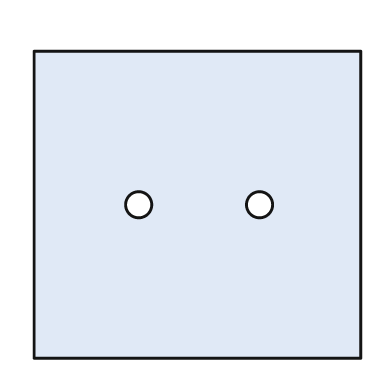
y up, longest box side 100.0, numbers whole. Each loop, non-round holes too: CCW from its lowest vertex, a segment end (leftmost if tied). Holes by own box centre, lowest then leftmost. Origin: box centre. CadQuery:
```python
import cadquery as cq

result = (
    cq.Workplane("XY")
    .moveTo(-50.0, -47.0)
    .lineTo(50.0, -47.0)
    .lineTo(50.0, 47.0)
    .lineTo(-50.0, 47.0)
    .close()
    .moveTo(-18.0, 0.0)
    .circle(4.0)
    .moveTo(19.0, 0.0)
    .circle(4.0)
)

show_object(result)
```